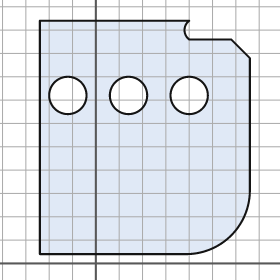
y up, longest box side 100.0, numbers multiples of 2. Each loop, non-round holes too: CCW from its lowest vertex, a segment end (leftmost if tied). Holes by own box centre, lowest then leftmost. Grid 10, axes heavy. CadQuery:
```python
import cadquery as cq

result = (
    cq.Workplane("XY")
    .moveTo(-24.0, 4.0)
    .lineTo(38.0, 4.0)
    .threePointArc((58.0, 12.0), (66.0, 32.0))
    .lineTo(66.0, 88.0)
    .lineTo(58.0, 96.0)
    .lineTo(40.0, 96.0)
    .threePointArc((38.0, 100.0), (40.0, 104.0))
    .lineTo(-24.0, 104.0)
    .close()
    .moveTo(-12.0, 72.0)
    .circle(8.0)
    .moveTo(14.0, 72.0)
    .circle(8.0)
    .moveTo(40.0, 72.0)
    .circle(8.0)
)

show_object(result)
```